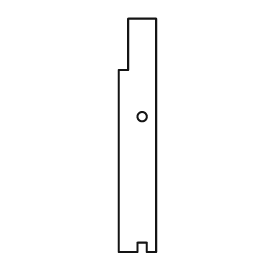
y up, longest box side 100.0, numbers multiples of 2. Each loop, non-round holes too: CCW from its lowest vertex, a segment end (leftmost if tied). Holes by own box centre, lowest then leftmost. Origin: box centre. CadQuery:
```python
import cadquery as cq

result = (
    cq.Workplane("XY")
    .moveTo(-8.0, -50.0)
    .lineTo(0.0, -50.0)
    .lineTo(0.0, -46.0)
    .lineTo(4.0, -46.0)
    .lineTo(4.0, -50.0)
    .lineTo(8.0, -50.0)
    .lineTo(8.0, 50.0)
    .lineTo(-4.0, 50.0)
    .lineTo(-4.0, 28.0)
    .lineTo(-8.0, 28.0)
    .close()
    .moveTo(2.0, 8.0)
    .circle(2.0)
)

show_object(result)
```